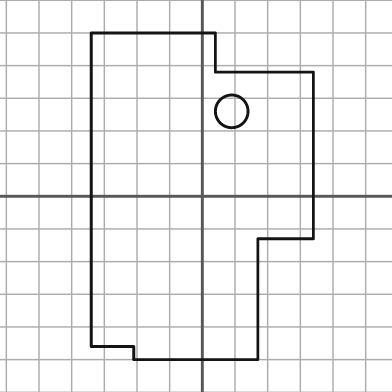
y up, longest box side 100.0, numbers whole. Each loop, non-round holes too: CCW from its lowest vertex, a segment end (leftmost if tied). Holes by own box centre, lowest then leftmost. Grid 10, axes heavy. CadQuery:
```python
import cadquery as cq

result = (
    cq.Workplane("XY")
    .moveTo(-21.0, -50.0)
    .lineTo(17.0, -50.0)
    .lineTo(17.0, -13.0)
    .lineTo(34.0, -13.0)
    .lineTo(34.0, 38.0)
    .lineTo(4.0, 38.0)
    .lineTo(4.0, 50.0)
    .lineTo(-34.0, 50.0)
    .lineTo(-34.0, -46.0)
    .lineTo(-21.0, -46.0)
    .close()
    .moveTo(9.0, 26.0)
    .circle(5.0)
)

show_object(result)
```